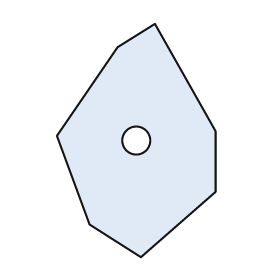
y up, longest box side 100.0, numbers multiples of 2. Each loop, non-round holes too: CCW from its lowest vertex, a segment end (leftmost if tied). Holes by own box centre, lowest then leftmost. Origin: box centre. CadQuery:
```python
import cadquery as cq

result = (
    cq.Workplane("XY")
    .moveTo(2.0, -50.0)
    .lineTo(34.0, -22.0)
    .lineTo(34.0, 4.0)
    .lineTo(8.0, 50.0)
    .lineTo(-8.0, 40.0)
    .lineTo(-34.0, 2.0)
    .lineTo(-20.0, -36.0)
    .close()
    .moveTo(0.0, 0.0)
    .circle(6.0)
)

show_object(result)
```